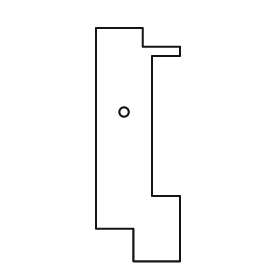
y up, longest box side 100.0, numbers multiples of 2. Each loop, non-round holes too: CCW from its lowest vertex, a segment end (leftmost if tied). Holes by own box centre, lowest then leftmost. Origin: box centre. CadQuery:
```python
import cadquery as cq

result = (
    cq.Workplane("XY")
    .moveTo(-2.0, -50.0)
    .lineTo(18.0, -50.0)
    .lineTo(18.0, -22.0)
    .lineTo(6.0, -22.0)
    .lineTo(6.0, 38.0)
    .lineTo(18.0, 38.0)
    .lineTo(18.0, 42.0)
    .lineTo(2.0, 42.0)
    .lineTo(2.0, 50.0)
    .lineTo(-18.0, 50.0)
    .lineTo(-18.0, -36.0)
    .lineTo(-2.0, -36.0)
    .close()
    .moveTo(-6.0, 14.0)
    .circle(2.0)
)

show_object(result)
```